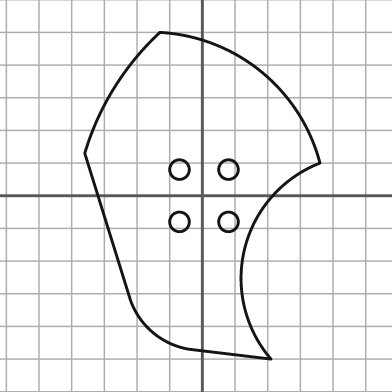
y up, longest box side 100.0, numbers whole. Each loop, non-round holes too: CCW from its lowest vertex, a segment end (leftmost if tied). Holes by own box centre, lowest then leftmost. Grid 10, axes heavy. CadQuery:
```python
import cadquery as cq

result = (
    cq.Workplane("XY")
    .moveTo(21.0, -50.0)
    .threePointArc((13.0, -16.0), (36.0, 10.0))
    .threePointArc((18.0, 38.0), (-13.0, 50.0))
    .threePointArc((-27.0, 33.0), (-36.0, 13.0))
    .lineTo(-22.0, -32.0)
    .threePointArc((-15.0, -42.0), (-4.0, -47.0))
    .close()
    .moveTo(-7.0, -8.0)
    .circle(3.0)
    .moveTo(8.0, -8.0)
    .circle(3.0)
    .moveTo(-7.0, 8.0)
    .circle(3.0)
    .moveTo(8.0, 8.0)
    .circle(3.0)
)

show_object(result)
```